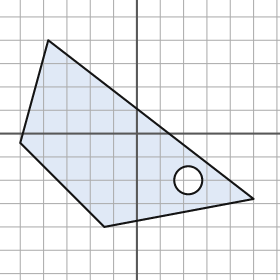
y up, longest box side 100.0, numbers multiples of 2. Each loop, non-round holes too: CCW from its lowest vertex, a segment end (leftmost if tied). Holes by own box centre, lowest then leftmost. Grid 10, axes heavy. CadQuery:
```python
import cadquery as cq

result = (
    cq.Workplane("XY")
    .moveTo(-14.0, -40.0)
    .lineTo(50.0, -28.0)
    .lineTo(-38.0, 40.0)
    .lineTo(-50.0, -4.0)
    .close()
    .moveTo(22.0, -20.0)
    .circle(6.0)
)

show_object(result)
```